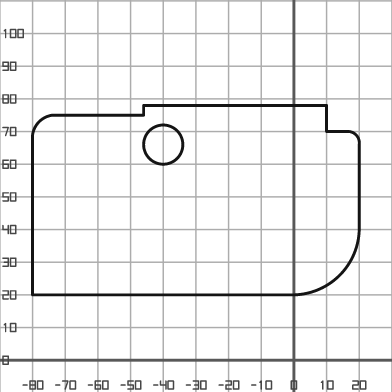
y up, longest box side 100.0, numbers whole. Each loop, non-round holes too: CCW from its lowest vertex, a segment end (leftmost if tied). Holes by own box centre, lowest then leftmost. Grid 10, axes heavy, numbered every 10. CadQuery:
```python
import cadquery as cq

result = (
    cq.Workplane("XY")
    .moveTo(-80.0, 20.0)
    .lineTo(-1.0, 20.0)
    .threePointArc((14.0, 26.0), (20.0, 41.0))
    .lineTo(20.0, 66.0)
    .threePointArc((19.0, 69.0), (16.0, 70.0))
    .lineTo(10.0, 70.0)
    .lineTo(10.0, 78.0)
    .lineTo(-46.0, 78.0)
    .lineTo(-46.0, 75.0)
    .lineTo(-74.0, 75.0)
    .threePointArc((-78.0, 73.0), (-80.0, 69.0))
    .close()
    .moveTo(-40.0, 66.0)
    .circle(6.0)
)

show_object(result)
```